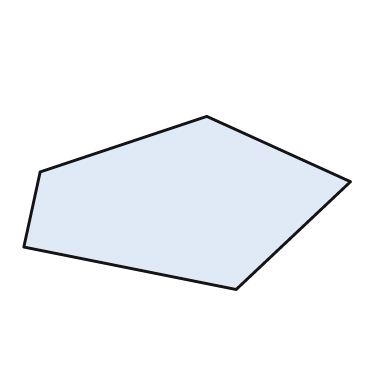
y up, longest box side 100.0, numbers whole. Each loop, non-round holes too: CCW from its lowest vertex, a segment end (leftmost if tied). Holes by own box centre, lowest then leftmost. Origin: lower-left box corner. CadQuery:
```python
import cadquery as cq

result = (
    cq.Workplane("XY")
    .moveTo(65.0, 0.0)
    .lineTo(100.0, 33.0)
    .lineTo(56.0, 53.0)
    .lineTo(5.0, 36.0)
    .lineTo(0.0, 13.0)
    .close()
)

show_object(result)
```